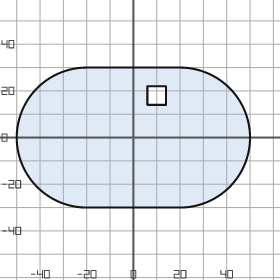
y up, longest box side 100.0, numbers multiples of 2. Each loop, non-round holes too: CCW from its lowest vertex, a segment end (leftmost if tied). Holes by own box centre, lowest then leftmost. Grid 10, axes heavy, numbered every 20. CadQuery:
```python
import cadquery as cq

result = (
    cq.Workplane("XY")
    .moveTo(-20.0, -30.0)
    .lineTo(20.0, -30.0)
    .threePointArc((50.0, 0.0), (20.0, 30.0))
    .lineTo(-20.0, 30.0)
    .threePointArc((-50.0, 0.0), (-20.0, -30.0))
    .close()
    .moveTo(6.0, 14.0)
    .lineTo(14.0, 14.0)
    .lineTo(14.0, 22.0)
    .lineTo(6.0, 22.0)
    .close()
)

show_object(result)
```